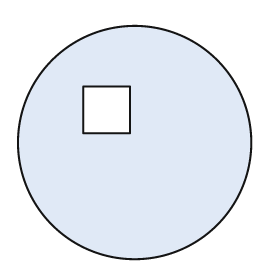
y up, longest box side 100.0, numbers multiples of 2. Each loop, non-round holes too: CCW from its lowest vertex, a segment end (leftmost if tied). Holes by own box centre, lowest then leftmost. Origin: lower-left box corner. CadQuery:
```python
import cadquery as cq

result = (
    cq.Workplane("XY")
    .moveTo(50.0, 50.0)
    .circle(50.0)
    .moveTo(28.0, 54.0)
    .lineTo(48.0, 54.0)
    .lineTo(48.0, 74.0)
    .lineTo(28.0, 74.0)
    .close()
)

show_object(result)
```